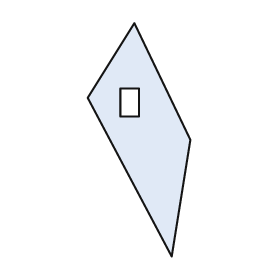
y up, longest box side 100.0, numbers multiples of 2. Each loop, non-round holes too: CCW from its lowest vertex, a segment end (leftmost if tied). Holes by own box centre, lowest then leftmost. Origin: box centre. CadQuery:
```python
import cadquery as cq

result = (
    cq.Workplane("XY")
    .moveTo(14.0, -50.0)
    .lineTo(22.0, 0.0)
    .lineTo(-2.0, 50.0)
    .lineTo(-22.0, 18.0)
    .close()
    .moveTo(-8.0, 10.0)
    .lineTo(0.0, 10.0)
    .lineTo(0.0, 22.0)
    .lineTo(-8.0, 22.0)
    .close()
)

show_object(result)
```